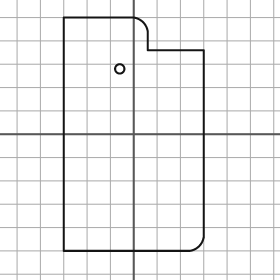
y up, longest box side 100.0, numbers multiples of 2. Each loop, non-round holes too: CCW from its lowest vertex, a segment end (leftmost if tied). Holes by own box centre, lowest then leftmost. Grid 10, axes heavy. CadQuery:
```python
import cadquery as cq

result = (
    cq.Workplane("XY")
    .moveTo(-30.0, -50.0)
    .lineTo(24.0, -50.0)
    .threePointArc((28.0, -48.0), (30.0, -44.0))
    .lineTo(30.0, 36.0)
    .lineTo(6.0, 36.0)
    .lineTo(6.0, 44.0)
    .threePointArc((4.0, 48.0), (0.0, 50.0))
    .lineTo(-30.0, 50.0)
    .close()
    .moveTo(-6.0, 28.0)
    .circle(2.0)
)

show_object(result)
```